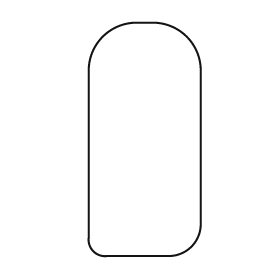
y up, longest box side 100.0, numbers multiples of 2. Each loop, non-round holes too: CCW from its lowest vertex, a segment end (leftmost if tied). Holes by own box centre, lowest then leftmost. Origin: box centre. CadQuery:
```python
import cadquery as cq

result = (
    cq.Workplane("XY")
    .moveTo(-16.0, -50.0)
    .lineTo(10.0, -50.0)
    .threePointArc((20.0, -46.0), (24.0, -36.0))
    .lineTo(24.0, 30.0)
    .threePointArc((18.0, 44.0), (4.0, 50.0))
    .lineTo(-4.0, 50.0)
    .threePointArc((-18.0, 44.0), (-24.0, 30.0))
    .lineTo(-24.0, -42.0)
    .threePointArc((-22.0, -48.0), (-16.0, -50.0))
    .close()
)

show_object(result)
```